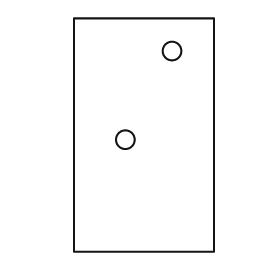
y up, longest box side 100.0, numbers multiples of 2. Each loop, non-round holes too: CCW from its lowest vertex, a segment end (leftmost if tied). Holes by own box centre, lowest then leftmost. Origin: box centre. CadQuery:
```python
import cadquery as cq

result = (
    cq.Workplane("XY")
    .moveTo(-30.0, -50.0)
    .lineTo(30.0, -50.0)
    .lineTo(30.0, 50.0)
    .lineTo(-30.0, 50.0)
    .close()
    .moveTo(-8.0, -2.0)
    .circle(4.0)
    .moveTo(12.0, 36.0)
    .circle(4.0)
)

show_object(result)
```